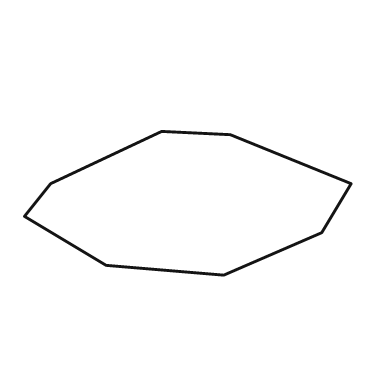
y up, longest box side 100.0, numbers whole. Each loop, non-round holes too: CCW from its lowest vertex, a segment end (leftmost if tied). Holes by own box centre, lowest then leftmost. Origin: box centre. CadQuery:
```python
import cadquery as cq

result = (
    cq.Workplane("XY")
    .moveTo(11.0, -22.0)
    .lineTo(41.0, -9.0)
    .lineTo(50.0, 6.0)
    .lineTo(13.0, 21.0)
    .lineTo(-8.0, 22.0)
    .lineTo(-42.0, 6.0)
    .lineTo(-50.0, -4.0)
    .lineTo(-25.0, -19.0)
    .close()
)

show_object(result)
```